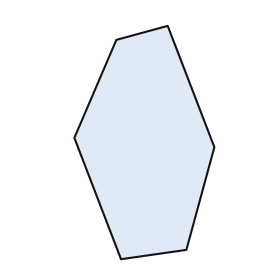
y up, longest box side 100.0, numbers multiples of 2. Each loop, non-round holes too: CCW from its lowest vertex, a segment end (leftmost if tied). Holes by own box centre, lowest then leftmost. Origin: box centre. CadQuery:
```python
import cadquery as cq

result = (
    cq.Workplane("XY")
    .moveTo(-10.0, -50.0)
    .lineTo(18.0, -46.0)
    .lineTo(30.0, -2.0)
    .lineTo(10.0, 50.0)
    .lineTo(-12.0, 44.0)
    .lineTo(-30.0, 2.0)
    .close()
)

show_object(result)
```